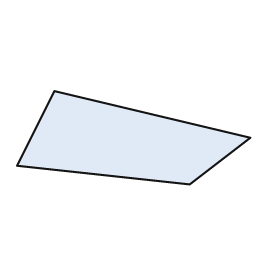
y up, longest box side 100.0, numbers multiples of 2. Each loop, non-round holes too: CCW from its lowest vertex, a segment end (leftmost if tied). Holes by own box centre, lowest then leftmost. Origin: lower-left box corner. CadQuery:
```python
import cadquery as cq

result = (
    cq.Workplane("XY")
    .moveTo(74.0, 0.0)
    .lineTo(100.0, 20.0)
    .lineTo(16.0, 40.0)
    .lineTo(0.0, 8.0)
    .close()
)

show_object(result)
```